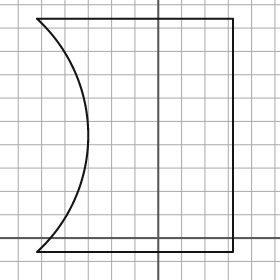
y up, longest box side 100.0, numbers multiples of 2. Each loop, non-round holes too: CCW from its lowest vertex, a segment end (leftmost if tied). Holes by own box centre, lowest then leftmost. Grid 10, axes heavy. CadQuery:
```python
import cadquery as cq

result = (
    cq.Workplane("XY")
    .moveTo(-52.0, -6.0)
    .lineTo(32.0, -6.0)
    .lineTo(32.0, 94.0)
    .lineTo(-52.0, 94.0)
    .threePointArc((-30.0, 44.0), (-52.0, -6.0))
    .close()
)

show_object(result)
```